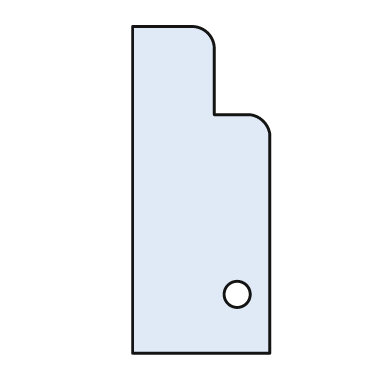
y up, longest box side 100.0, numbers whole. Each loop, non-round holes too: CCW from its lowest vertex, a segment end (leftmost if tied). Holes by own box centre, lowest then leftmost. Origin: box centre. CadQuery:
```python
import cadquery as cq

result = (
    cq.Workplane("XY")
    .moveTo(-21.0, -50.0)
    .lineTo(21.0, -50.0)
    .lineTo(21.0, 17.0)
    .threePointArc((19.0, 21.0), (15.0, 23.0))
    .lineTo(4.0, 23.0)
    .lineTo(4.0, 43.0)
    .threePointArc((2.0, 48.0), (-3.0, 50.0))
    .lineTo(-21.0, 50.0)
    .close()
    .moveTo(11.0, -32.0)
    .circle(4.0)
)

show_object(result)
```